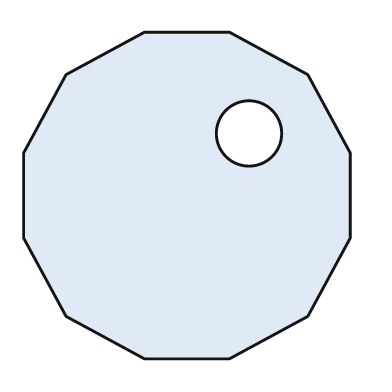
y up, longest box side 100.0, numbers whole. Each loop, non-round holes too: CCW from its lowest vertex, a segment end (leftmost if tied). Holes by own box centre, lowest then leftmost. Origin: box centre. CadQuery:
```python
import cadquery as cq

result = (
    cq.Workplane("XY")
    .moveTo(-13.0, -50.0)
    .lineTo(13.0, -50.0)
    .lineTo(37.0, -37.0)
    .lineTo(50.0, -13.0)
    .lineTo(50.0, 13.0)
    .lineTo(37.0, 37.0)
    .lineTo(13.0, 50.0)
    .lineTo(-13.0, 50.0)
    .lineTo(-37.0, 37.0)
    .lineTo(-50.0, 13.0)
    .lineTo(-50.0, -13.0)
    .lineTo(-37.0, -37.0)
    .close()
    .moveTo(19.0, 19.0)
    .circle(10.0)
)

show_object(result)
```